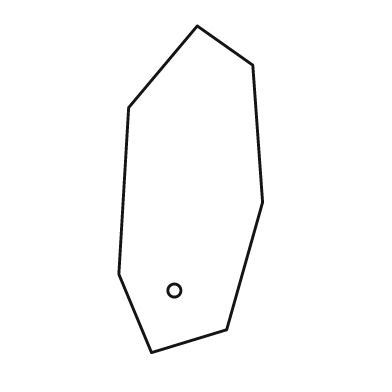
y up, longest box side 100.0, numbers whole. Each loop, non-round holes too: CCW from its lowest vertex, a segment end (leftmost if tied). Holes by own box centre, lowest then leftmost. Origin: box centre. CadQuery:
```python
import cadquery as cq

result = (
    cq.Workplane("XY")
    .moveTo(-12.0, -50.0)
    .lineTo(11.0, -43.0)
    .lineTo(22.0, -4.0)
    .lineTo(19.0, 38.0)
    .lineTo(2.0, 50.0)
    .lineTo(-19.0, 25.0)
    .lineTo(-22.0, -26.0)
    .close()
    .moveTo(-5.0, -31.0)
    .circle(2.0)
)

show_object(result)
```